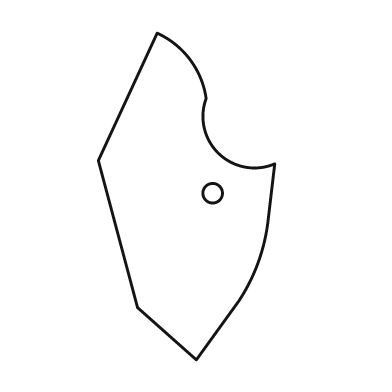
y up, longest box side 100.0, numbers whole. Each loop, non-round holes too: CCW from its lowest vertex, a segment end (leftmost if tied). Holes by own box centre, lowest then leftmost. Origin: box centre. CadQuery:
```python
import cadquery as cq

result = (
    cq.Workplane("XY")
    .moveTo(3.0, -50.0)
    .lineTo(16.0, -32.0)
    .threePointArc((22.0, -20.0), (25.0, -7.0))
    .lineTo(27.0, 10.0)
    .threePointArc((10.0, 13.0), (6.0, 30.0))
    .threePointArc((1.0, 42.0), (-9.0, 50.0))
    .lineTo(-27.0, 11.0)
    .lineTo(-15.0, -34.0)
    .close()
    .moveTo(8.0, 1.0)
    .circle(3.0)
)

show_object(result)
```